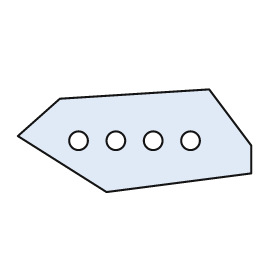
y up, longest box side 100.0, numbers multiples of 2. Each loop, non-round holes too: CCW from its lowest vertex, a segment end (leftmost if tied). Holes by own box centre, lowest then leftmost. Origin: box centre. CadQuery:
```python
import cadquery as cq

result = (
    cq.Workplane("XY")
    .moveTo(-12.0, -22.0)
    .lineTo(50.0, -14.0)
    .lineTo(50.0, -2.0)
    .lineTo(32.0, 22.0)
    .lineTo(-32.0, 18.0)
    .lineTo(-50.0, 2.0)
    .close()
    .moveTo(-24.0, 0.0)
    .circle(4.0)
    .moveTo(-8.0, 0.0)
    .circle(4.0)
    .moveTo(8.0, 0.0)
    .circle(4.0)
    .moveTo(24.0, 0.0)
    .circle(4.0)
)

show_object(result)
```